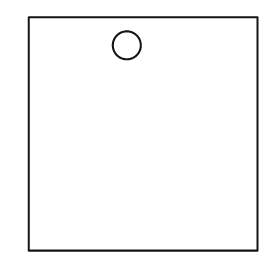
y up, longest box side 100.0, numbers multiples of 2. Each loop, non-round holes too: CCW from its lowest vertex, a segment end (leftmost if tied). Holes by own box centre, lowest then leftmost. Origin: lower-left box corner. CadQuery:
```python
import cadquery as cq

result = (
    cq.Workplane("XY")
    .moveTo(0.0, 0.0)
    .lineTo(98.0, 0.0)
    .lineTo(98.0, 100.0)
    .lineTo(0.0, 100.0)
    .close()
    .moveTo(42.0, 88.0)
    .circle(6.0)
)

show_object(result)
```